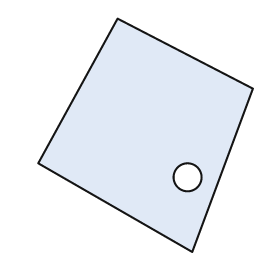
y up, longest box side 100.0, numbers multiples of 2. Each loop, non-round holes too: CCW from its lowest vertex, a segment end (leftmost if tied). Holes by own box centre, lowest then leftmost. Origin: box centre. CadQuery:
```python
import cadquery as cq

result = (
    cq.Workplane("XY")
    .moveTo(20.0, -50.0)
    .lineTo(46.0, 20.0)
    .lineTo(-12.0, 50.0)
    .lineTo(-46.0, -12.0)
    .close()
    .moveTo(18.0, -18.0)
    .circle(6.0)
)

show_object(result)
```